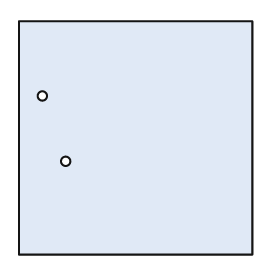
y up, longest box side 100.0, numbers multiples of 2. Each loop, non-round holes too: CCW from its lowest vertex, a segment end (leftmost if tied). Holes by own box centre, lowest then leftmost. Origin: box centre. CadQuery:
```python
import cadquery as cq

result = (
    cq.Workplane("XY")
    .moveTo(-50.0, -50.0)
    .lineTo(50.0, -50.0)
    .lineTo(50.0, 50.0)
    .lineTo(-50.0, 50.0)
    .close()
    .moveTo(-30.0, -10.0)
    .circle(2.0)
    .moveTo(-40.0, 18.0)
    .circle(2.0)
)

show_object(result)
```